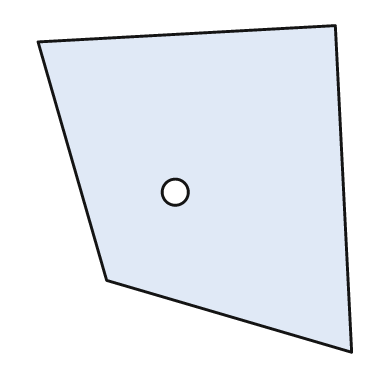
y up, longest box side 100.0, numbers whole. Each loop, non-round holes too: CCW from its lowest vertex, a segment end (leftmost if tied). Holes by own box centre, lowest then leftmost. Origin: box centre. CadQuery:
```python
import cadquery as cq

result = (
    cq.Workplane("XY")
    .moveTo(48.0, -50.0)
    .lineTo(43.0, 50.0)
    .lineTo(-48.0, 45.0)
    .lineTo(-27.0, -28.0)
    .close()
    .moveTo(-6.0, -1.0)
    .circle(4.0)
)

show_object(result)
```